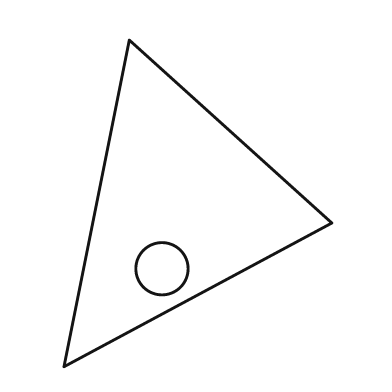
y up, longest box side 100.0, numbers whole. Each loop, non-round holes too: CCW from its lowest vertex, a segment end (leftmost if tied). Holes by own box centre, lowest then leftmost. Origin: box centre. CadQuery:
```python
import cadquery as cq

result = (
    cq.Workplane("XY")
    .moveTo(-41.0, -50.0)
    .lineTo(41.0, -6.0)
    .lineTo(-21.0, 50.0)
    .close()
    .moveTo(-11.0, -20.0)
    .circle(8.0)
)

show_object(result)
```